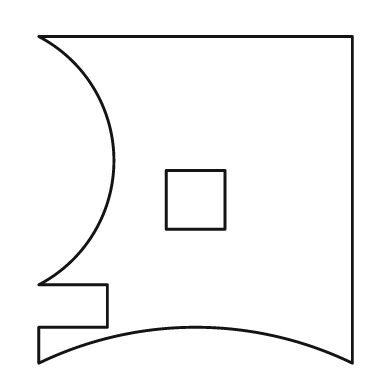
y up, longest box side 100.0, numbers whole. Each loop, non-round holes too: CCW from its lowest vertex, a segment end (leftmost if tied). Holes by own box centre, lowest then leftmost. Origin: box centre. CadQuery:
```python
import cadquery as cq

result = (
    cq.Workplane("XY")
    .moveTo(-48.0, -50.0)
    .threePointArc((0.0, -39.0), (48.0, -50.0))
    .lineTo(48.0, 50.0)
    .lineTo(-48.0, 50.0)
    .threePointArc((-25.0, 12.0), (-48.0, -26.0))
    .lineTo(-27.0, -26.0)
    .lineTo(-27.0, -39.0)
    .lineTo(-48.0, -39.0)
    .close()
    .moveTo(-9.0, -9.0)
    .lineTo(9.0, -9.0)
    .lineTo(9.0, 9.0)
    .lineTo(-9.0, 9.0)
    .close()
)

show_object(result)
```